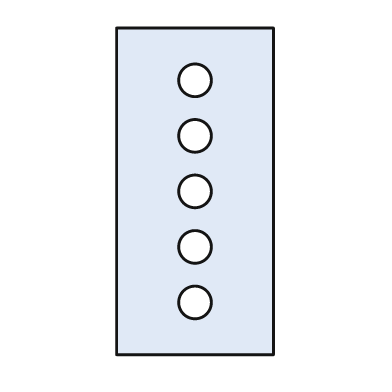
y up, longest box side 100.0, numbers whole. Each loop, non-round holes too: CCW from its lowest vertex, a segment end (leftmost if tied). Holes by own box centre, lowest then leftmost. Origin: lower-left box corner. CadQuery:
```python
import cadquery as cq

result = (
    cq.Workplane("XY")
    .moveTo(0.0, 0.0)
    .lineTo(48.0, 0.0)
    .lineTo(48.0, 100.0)
    .lineTo(0.0, 100.0)
    .close()
    .moveTo(24.0, 16.0)
    .circle(5.0)
    .moveTo(24.0, 33.0)
    .circle(5.0)
    .moveTo(24.0, 50.0)
    .circle(5.0)
    .moveTo(24.0, 67.0)
    .circle(5.0)
    .moveTo(24.0, 84.0)
    .circle(5.0)
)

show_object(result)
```